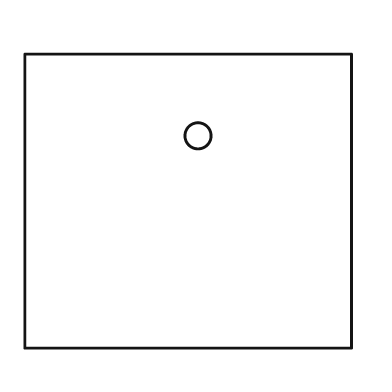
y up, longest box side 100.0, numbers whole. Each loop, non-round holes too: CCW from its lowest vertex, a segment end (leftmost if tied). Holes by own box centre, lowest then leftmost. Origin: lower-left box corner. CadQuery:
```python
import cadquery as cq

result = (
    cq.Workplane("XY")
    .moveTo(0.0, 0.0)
    .lineTo(100.0, 0.0)
    .lineTo(100.0, 90.0)
    .lineTo(0.0, 90.0)
    .close()
    .moveTo(53.0, 65.0)
    .circle(4.0)
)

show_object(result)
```